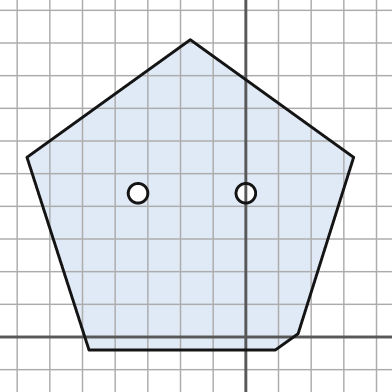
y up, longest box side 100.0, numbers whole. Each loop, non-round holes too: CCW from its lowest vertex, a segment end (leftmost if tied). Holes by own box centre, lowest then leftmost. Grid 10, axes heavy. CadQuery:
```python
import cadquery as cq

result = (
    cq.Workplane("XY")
    .moveTo(-48.0, -4.0)
    .lineTo(9.0, -4.0)
    .lineTo(16.0, 1.0)
    .lineTo(33.0, 55.0)
    .lineTo(-17.0, 91.0)
    .lineTo(-67.0, 55.0)
    .close()
    .moveTo(-33.0, 44.0)
    .circle(3.0)
    .moveTo(0.0, 44.0)
    .circle(3.0)
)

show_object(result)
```